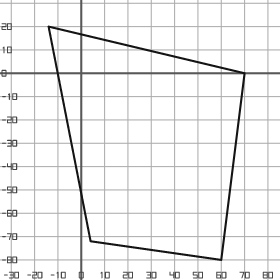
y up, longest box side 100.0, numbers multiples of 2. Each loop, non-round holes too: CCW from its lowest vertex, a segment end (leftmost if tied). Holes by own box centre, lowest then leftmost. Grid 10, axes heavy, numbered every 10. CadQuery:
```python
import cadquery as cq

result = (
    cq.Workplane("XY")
    .moveTo(60.0, -80.0)
    .lineTo(70.0, 0.0)
    .lineTo(-14.0, 20.0)
    .lineTo(4.0, -72.0)
    .close()
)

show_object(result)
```